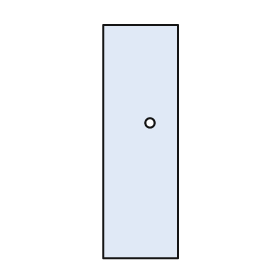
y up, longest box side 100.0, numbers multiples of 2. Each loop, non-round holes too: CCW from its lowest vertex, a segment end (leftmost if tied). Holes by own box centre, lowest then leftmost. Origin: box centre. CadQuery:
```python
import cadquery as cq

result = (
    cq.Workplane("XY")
    .moveTo(-16.0, -50.0)
    .lineTo(16.0, -50.0)
    .lineTo(16.0, 50.0)
    .lineTo(-16.0, 50.0)
    .close()
    .moveTo(4.0, 8.0)
    .circle(2.0)
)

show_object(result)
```